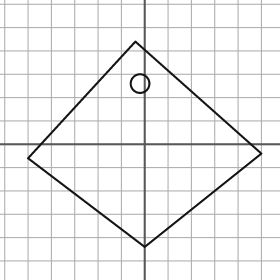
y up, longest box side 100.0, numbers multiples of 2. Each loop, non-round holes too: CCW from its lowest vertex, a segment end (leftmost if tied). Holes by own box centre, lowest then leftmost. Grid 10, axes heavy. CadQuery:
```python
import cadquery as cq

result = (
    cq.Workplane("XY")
    .moveTo(0.0, -44.0)
    .lineTo(50.0, -4.0)
    .lineTo(-4.0, 44.0)
    .lineTo(-50.0, -6.0)
    .close()
    .moveTo(-2.0, 26.0)
    .circle(4.0)
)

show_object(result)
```